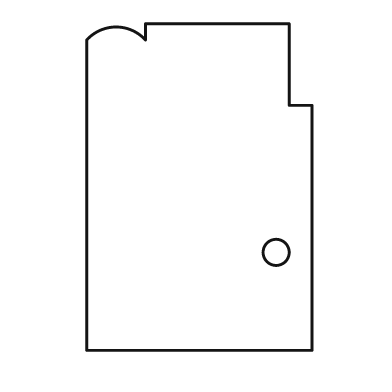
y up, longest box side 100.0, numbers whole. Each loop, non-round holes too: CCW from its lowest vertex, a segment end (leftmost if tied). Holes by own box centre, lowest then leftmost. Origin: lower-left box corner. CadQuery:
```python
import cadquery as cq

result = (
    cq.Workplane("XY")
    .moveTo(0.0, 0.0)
    .lineTo(69.0, 0.0)
    .lineTo(69.0, 75.0)
    .lineTo(62.0, 75.0)
    .lineTo(62.0, 100.0)
    .lineTo(18.0, 100.0)
    .lineTo(18.0, 95.0)
    .threePointArc((9.0, 99.0), (0.0, 95.0))
    .close()
    .moveTo(58.0, 30.0)
    .circle(4.0)
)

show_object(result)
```